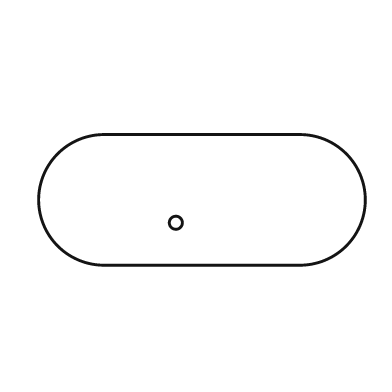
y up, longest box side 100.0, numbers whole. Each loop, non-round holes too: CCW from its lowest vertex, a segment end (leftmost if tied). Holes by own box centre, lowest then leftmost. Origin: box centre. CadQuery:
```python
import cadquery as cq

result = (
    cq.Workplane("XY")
    .moveTo(-30.0, -20.0)
    .lineTo(30.0, -20.0)
    .threePointArc((50.0, 0.0), (30.0, 20.0))
    .lineTo(-30.0, 20.0)
    .threePointArc((-50.0, 0.0), (-30.0, -20.0))
    .close()
    .moveTo(-8.0, -7.0)
    .circle(2.0)
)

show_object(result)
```